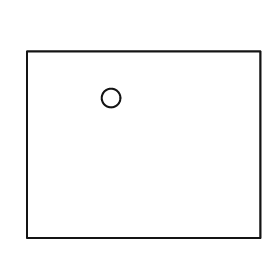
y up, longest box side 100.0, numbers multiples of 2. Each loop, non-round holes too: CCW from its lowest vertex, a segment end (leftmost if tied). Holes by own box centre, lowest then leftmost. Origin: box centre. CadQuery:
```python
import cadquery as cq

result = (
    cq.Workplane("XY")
    .moveTo(-50.0, -40.0)
    .lineTo(50.0, -40.0)
    .lineTo(50.0, 40.0)
    .lineTo(-50.0, 40.0)
    .close()
    .moveTo(-14.0, 20.0)
    .circle(4.0)
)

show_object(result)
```